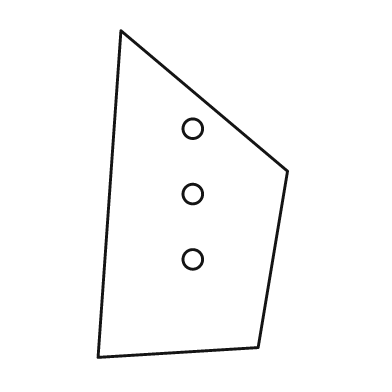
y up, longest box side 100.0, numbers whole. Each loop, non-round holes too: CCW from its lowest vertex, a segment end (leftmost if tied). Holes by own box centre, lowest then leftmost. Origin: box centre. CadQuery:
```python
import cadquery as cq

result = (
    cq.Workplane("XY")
    .moveTo(-29.0, -50.0)
    .lineTo(20.0, -47.0)
    .lineTo(29.0, 7.0)
    .lineTo(-22.0, 50.0)
    .close()
    .moveTo(0.0, -20.0)
    .circle(3.0)
    .moveTo(0.0, 0.0)
    .circle(3.0)
    .moveTo(0.0, 20.0)
    .circle(3.0)
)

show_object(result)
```